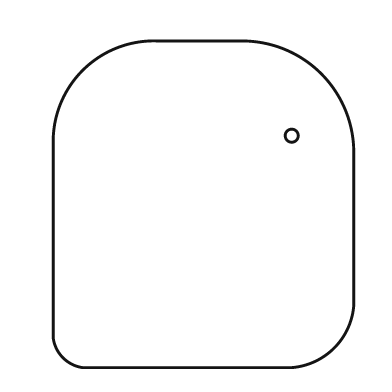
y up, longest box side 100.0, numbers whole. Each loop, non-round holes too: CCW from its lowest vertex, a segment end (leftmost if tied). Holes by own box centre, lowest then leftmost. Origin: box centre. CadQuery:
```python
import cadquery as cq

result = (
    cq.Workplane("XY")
    .moveTo(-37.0, -50.0)
    .lineTo(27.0, -50.0)
    .threePointArc((40.0, -44.0), (46.0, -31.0))
    .lineTo(46.0, 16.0)
    .threePointArc((36.0, 40.0), (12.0, 50.0))
    .lineTo(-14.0, 50.0)
    .threePointArc((-37.0, 41.0), (-46.0, 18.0))
    .lineTo(-46.0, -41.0)
    .threePointArc((-43.0, -47.0), (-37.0, -50.0))
    .close()
    .moveTo(27.0, 21.0)
    .circle(2.0)
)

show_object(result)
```